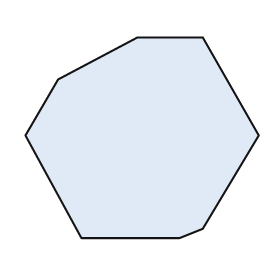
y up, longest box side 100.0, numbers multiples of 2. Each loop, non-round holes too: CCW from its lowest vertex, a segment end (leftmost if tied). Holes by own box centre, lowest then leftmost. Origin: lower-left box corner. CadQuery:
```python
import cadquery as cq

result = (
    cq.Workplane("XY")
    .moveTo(24.0, 0.0)
    .lineTo(66.0, 0.0)
    .lineTo(76.0, 4.0)
    .lineTo(100.0, 44.0)
    .lineTo(76.0, 86.0)
    .lineTo(48.0, 86.0)
    .lineTo(14.0, 68.0)
    .lineTo(0.0, 44.0)
    .close()
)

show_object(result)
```